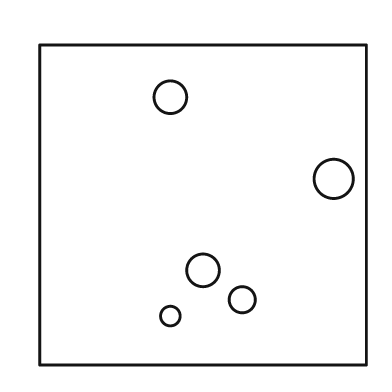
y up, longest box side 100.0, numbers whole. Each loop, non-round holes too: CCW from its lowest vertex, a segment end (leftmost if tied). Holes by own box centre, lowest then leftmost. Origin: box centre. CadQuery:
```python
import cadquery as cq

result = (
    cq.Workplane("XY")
    .moveTo(-50.0, -49.0)
    .lineTo(50.0, -49.0)
    .lineTo(50.0, 49.0)
    .lineTo(-50.0, 49.0)
    .close()
    .moveTo(-10.0, -34.0)
    .circle(3.0)
    .moveTo(12.0, -29.0)
    .circle(4.0)
    .moveTo(0.0, -20.0)
    .circle(5.0)
    .moveTo(40.0, 8.0)
    .circle(6.0)
    .moveTo(-10.0, 33.0)
    .circle(5.0)
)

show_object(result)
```